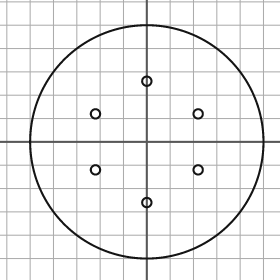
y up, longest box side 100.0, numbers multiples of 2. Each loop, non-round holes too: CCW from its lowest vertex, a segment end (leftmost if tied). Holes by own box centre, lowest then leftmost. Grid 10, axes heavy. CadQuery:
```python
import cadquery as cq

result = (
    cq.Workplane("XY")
    .moveTo(0.0, 0.0)
    .circle(50.0)
    .moveTo(0.0, -26.0)
    .circle(2.0)
    .moveTo(-22.0, -12.0)
    .circle(2.0)
    .moveTo(22.0, -12.0)
    .circle(2.0)
    .moveTo(-22.0, 12.0)
    .circle(2.0)
    .moveTo(22.0, 12.0)
    .circle(2.0)
    .moveTo(0.0, 26.0)
    .circle(2.0)
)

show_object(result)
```